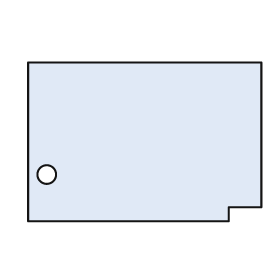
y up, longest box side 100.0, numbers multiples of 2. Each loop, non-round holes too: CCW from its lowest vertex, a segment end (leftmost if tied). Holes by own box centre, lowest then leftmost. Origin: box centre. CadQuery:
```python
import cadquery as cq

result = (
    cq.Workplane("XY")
    .moveTo(-50.0, -34.0)
    .lineTo(36.0, -34.0)
    .lineTo(36.0, -28.0)
    .lineTo(50.0, -28.0)
    .lineTo(50.0, 34.0)
    .lineTo(-50.0, 34.0)
    .close()
    .moveTo(-42.0, -14.0)
    .circle(4.0)
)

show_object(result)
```